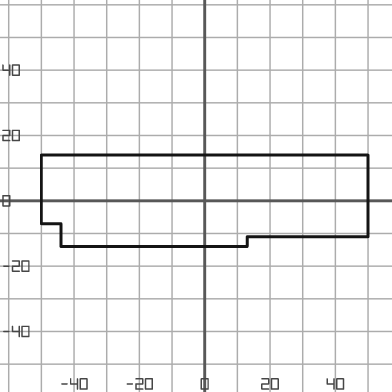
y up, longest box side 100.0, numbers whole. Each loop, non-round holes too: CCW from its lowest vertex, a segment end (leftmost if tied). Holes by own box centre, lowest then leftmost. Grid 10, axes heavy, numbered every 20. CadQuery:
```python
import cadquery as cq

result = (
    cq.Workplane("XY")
    .moveTo(-44.0, -14.0)
    .lineTo(13.0, -14.0)
    .lineTo(13.0, -11.0)
    .lineTo(50.0, -11.0)
    .lineTo(50.0, 14.0)
    .lineTo(-50.0, 14.0)
    .lineTo(-50.0, -7.0)
    .lineTo(-44.0, -7.0)
    .close()
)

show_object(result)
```